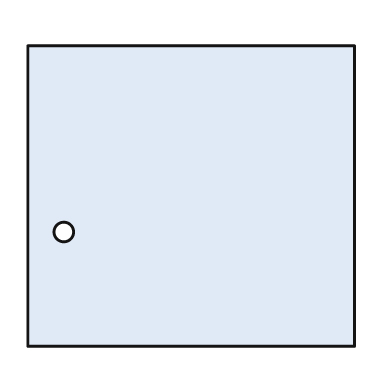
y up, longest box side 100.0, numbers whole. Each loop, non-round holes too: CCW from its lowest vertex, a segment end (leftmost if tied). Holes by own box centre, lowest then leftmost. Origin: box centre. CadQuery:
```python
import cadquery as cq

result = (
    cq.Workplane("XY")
    .moveTo(-50.0, -46.0)
    .lineTo(50.0, -46.0)
    .lineTo(50.0, 46.0)
    .lineTo(-50.0, 46.0)
    .close()
    .moveTo(-39.0, -11.0)
    .circle(3.0)
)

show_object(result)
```